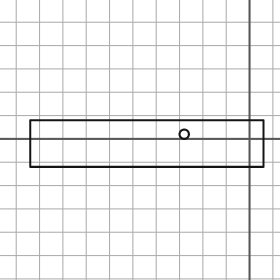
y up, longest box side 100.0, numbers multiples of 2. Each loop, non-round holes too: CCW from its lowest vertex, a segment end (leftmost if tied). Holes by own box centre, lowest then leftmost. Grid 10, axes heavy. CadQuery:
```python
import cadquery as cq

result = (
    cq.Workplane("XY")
    .moveTo(-94.0, -12.0)
    .lineTo(6.0, -12.0)
    .lineTo(6.0, 8.0)
    .lineTo(-94.0, 8.0)
    .close()
    .moveTo(-28.0, 2.0)
    .circle(2.0)
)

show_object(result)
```